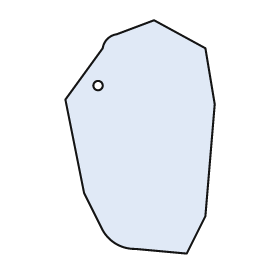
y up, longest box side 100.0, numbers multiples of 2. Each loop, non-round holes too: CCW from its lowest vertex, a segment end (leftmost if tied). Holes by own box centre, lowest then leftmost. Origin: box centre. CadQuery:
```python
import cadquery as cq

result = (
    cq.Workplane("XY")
    .moveTo(20.0, -50.0)
    .lineTo(28.0, -34.0)
    .lineTo(32.0, 14.0)
    .lineTo(28.0, 38.0)
    .lineTo(6.0, 50.0)
    .lineTo(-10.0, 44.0)
    .threePointArc((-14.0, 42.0), (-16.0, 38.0))
    .lineTo(-32.0, 16.0)
    .lineTo(-24.0, -24.0)
    .lineTo(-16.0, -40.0)
    .threePointArc((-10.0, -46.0), (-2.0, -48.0))
    .close()
    .moveTo(-18.0, 22.0)
    .circle(2.0)
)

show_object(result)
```